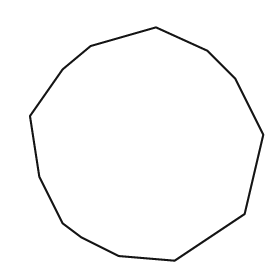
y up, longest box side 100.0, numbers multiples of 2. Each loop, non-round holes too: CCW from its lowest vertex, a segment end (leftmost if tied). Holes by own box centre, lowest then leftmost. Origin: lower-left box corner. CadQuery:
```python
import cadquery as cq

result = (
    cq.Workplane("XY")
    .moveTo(62.0, 0.0)
    .lineTo(92.0, 20.0)
    .lineTo(100.0, 54.0)
    .lineTo(88.0, 78.0)
    .lineTo(76.0, 90.0)
    .lineTo(54.0, 100.0)
    .lineTo(26.0, 92.0)
    .lineTo(14.0, 82.0)
    .lineTo(0.0, 62.0)
    .lineTo(4.0, 36.0)
    .lineTo(14.0, 16.0)
    .lineTo(22.0, 10.0)
    .lineTo(38.0, 2.0)
    .close()
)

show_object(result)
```